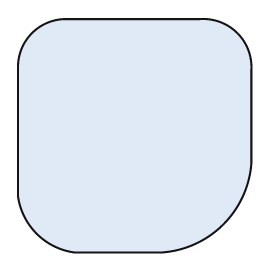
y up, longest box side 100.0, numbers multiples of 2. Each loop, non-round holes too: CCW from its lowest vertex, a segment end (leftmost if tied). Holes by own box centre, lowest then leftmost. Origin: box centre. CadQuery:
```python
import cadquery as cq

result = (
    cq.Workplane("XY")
    .moveTo(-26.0, -50.0)
    .lineTo(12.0, -50.0)
    .threePointArc((38.0, -38.0), (50.0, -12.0))
    .lineTo(50.0, 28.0)
    .threePointArc((44.0, 44.0), (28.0, 50.0))
    .lineTo(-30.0, 50.0)
    .threePointArc((-44.0, 44.0), (-50.0, 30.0))
    .lineTo(-50.0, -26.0)
    .threePointArc((-42.0, -42.0), (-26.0, -50.0))
    .close()
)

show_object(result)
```